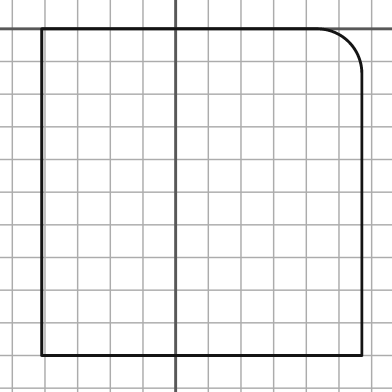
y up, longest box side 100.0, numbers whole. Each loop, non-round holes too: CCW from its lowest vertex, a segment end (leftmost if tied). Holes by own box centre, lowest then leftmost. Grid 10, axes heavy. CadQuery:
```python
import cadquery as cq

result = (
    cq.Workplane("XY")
    .moveTo(-41.0, -100.0)
    .lineTo(57.0, -100.0)
    .lineTo(57.0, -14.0)
    .threePointArc((53.0, -4.0), (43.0, 0.0))
    .lineTo(-41.0, 0.0)
    .close()
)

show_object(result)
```